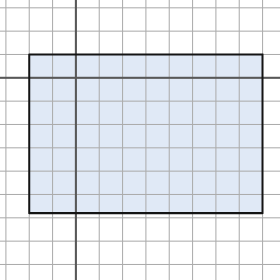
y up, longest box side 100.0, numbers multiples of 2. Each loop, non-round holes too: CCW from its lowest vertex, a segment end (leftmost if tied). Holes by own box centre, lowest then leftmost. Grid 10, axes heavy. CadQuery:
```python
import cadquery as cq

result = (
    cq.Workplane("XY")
    .moveTo(-20.0, -58.0)
    .lineTo(80.0, -58.0)
    .lineTo(80.0, 10.0)
    .lineTo(-20.0, 10.0)
    .close()
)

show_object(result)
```